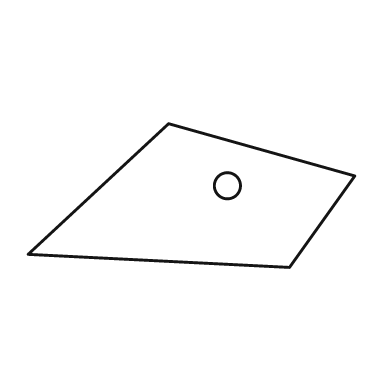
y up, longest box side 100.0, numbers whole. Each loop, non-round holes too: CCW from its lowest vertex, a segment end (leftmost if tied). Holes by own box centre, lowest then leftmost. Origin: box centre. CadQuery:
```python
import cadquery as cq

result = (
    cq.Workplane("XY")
    .moveTo(30.0, -22.0)
    .lineTo(50.0, 6.0)
    .lineTo(-7.0, 22.0)
    .lineTo(-50.0, -18.0)
    .close()
    .moveTo(11.0, 3.0)
    .circle(4.0)
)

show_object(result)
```